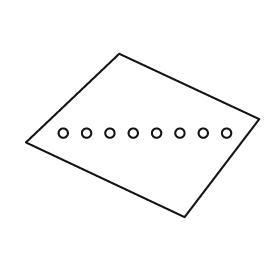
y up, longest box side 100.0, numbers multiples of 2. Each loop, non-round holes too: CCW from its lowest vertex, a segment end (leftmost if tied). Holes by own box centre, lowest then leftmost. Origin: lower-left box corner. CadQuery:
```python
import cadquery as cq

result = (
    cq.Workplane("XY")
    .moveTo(68.0, 0.0)
    .lineTo(100.0, 42.0)
    .lineTo(40.0, 70.0)
    .lineTo(0.0, 32.0)
    .close()
    .moveTo(16.0, 36.0)
    .circle(2.0)
    .moveTo(26.0, 36.0)
    .circle(2.0)
    .moveTo(36.0, 36.0)
    .circle(2.0)
    .moveTo(46.0, 36.0)
    .circle(2.0)
    .moveTo(56.0, 36.0)
    .circle(2.0)
    .moveTo(66.0, 36.0)
    .circle(2.0)
    .moveTo(76.0, 36.0)
    .circle(2.0)
    .moveTo(86.0, 36.0)
    .circle(2.0)
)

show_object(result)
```